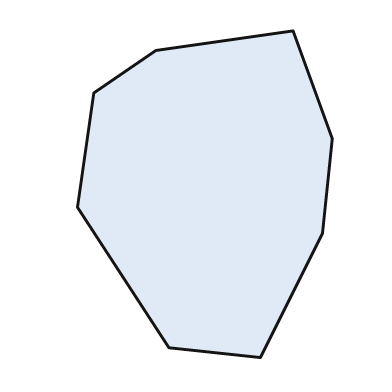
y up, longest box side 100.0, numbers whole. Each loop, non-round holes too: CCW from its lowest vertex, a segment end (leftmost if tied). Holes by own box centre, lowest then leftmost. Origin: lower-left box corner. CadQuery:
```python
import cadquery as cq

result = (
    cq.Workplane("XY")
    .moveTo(56.0, 0.0)
    .lineTo(75.0, 38.0)
    .lineTo(78.0, 67.0)
    .lineTo(66.0, 100.0)
    .lineTo(24.0, 94.0)
    .lineTo(5.0, 81.0)
    .lineTo(0.0, 46.0)
    .lineTo(28.0, 3.0)
    .close()
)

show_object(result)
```